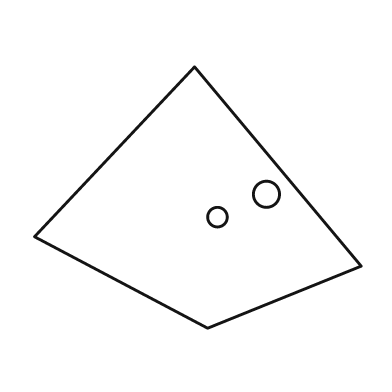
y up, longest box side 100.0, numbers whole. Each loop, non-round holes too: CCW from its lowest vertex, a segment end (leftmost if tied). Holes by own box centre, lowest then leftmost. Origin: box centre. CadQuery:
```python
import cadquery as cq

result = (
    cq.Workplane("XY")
    .moveTo(3.0, -40.0)
    .lineTo(50.0, -21.0)
    .lineTo(-1.0, 40.0)
    .lineTo(-50.0, -12.0)
    .close()
    .moveTo(6.0, -6.0)
    .circle(3.0)
    .moveTo(21.0, 1.0)
    .circle(4.0)
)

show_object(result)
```